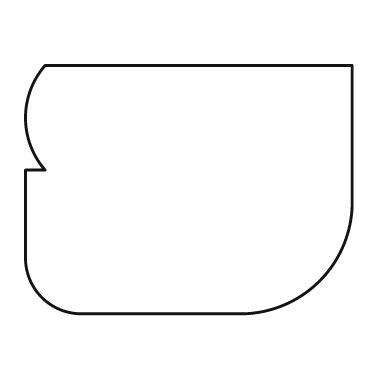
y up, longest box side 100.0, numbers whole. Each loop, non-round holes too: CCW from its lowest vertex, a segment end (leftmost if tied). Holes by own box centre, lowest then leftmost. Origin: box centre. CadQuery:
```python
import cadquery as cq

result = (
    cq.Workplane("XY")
    .moveTo(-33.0, -38.0)
    .lineTo(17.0, -38.0)
    .threePointArc((40.0, -28.0), (50.0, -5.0))
    .lineTo(50.0, 38.0)
    .lineTo(-44.0, 38.0)
    .threePointArc((-50.0, 22.0), (-44.0, 6.0))
    .lineTo(-50.0, 6.0)
    .lineTo(-50.0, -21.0)
    .threePointArc((-45.0, -33.0), (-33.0, -38.0))
    .close()
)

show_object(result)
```